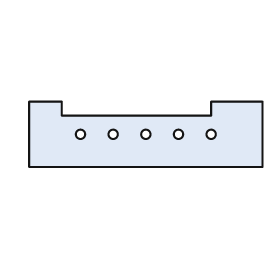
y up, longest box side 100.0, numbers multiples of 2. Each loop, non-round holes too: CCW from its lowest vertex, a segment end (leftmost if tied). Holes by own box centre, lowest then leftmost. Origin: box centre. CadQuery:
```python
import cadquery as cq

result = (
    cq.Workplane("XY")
    .moveTo(-50.0, -14.0)
    .lineTo(50.0, -14.0)
    .lineTo(50.0, 14.0)
    .lineTo(28.0, 14.0)
    .lineTo(28.0, 8.0)
    .lineTo(-36.0, 8.0)
    .lineTo(-36.0, 14.0)
    .lineTo(-50.0, 14.0)
    .close()
    .moveTo(-28.0, 0.0)
    .circle(2.0)
    .moveTo(-14.0, 0.0)
    .circle(2.0)
    .moveTo(0.0, 0.0)
    .circle(2.0)
    .moveTo(14.0, 0.0)
    .circle(2.0)
    .moveTo(28.0, 0.0)
    .circle(2.0)
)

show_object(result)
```